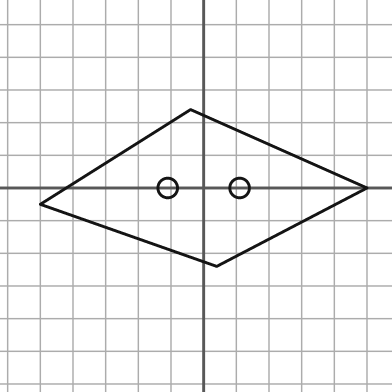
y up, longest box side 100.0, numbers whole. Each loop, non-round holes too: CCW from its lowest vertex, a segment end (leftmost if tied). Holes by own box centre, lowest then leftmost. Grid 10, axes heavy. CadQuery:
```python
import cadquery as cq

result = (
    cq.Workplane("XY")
    .moveTo(4.0, -24.0)
    .lineTo(50.0, 0.0)
    .lineTo(-4.0, 24.0)
    .lineTo(-50.0, -5.0)
    .close()
    .moveTo(-11.0, 0.0)
    .circle(3.0)
    .moveTo(11.0, 0.0)
    .circle(3.0)
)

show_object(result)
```